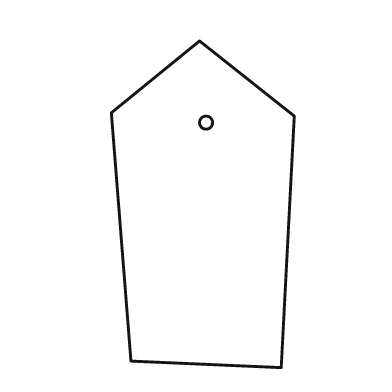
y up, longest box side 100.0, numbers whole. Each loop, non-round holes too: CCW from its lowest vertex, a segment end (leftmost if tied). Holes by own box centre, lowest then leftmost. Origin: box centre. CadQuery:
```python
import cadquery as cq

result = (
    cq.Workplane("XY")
    .moveTo(24.0, -50.0)
    .lineTo(28.0, 27.0)
    .lineTo(-1.0, 50.0)
    .lineTo(-28.0, 28.0)
    .lineTo(-22.0, -48.0)
    .close()
    .moveTo(1.0, 25.0)
    .circle(2.0)
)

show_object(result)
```